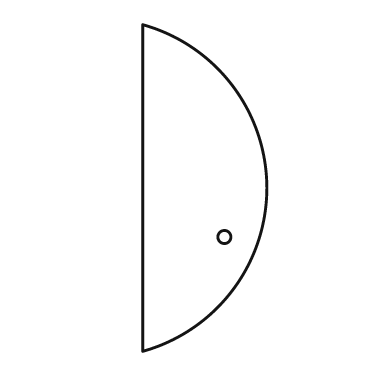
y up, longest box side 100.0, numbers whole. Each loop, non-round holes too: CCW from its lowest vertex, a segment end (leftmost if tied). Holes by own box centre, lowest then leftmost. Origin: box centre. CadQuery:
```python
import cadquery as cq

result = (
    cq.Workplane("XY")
    .moveTo(-19.0, -50.0)
    .threePointArc((19.0, 0.0), (-19.0, 50.0))
    .close()
    .moveTo(6.0, -15.0)
    .circle(2.0)
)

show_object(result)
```